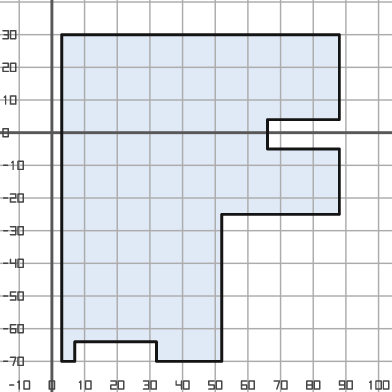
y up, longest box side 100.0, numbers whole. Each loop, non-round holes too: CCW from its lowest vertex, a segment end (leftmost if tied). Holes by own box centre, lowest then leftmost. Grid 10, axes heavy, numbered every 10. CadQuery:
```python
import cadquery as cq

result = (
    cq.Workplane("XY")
    .moveTo(3.0, -70.0)
    .lineTo(7.0, -70.0)
    .lineTo(7.0, -64.0)
    .lineTo(32.0, -64.0)
    .lineTo(32.0, -70.0)
    .lineTo(52.0, -70.0)
    .lineTo(52.0, -25.0)
    .lineTo(88.0, -25.0)
    .lineTo(88.0, -5.0)
    .lineTo(66.0, -5.0)
    .lineTo(66.0, 4.0)
    .lineTo(88.0, 4.0)
    .lineTo(88.0, 30.0)
    .lineTo(3.0, 30.0)
    .close()
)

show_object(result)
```